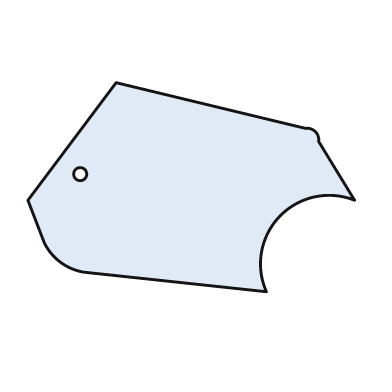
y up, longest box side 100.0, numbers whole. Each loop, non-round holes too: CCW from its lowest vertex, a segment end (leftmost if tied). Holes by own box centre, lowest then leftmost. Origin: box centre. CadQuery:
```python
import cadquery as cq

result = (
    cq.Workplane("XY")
    .moveTo(23.0, -32.0)
    .threePointArc((27.0, -9.0), (50.0, -4.0))
    .lineTo(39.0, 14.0)
    .threePointArc((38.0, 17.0), (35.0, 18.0))
    .lineTo(-23.0, 32.0)
    .lineTo(-50.0, -4.0)
    .lineTo(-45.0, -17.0)
    .threePointArc((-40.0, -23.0), (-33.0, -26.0))
    .close()
    .moveTo(-34.0, 4.0)
    .circle(2.0)
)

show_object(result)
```